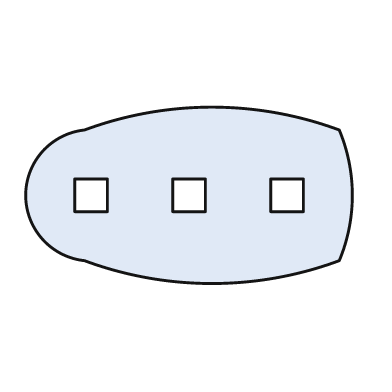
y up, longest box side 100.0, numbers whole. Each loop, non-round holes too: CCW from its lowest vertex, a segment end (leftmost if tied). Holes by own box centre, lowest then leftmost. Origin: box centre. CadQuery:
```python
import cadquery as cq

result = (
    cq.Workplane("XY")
    .moveTo(-32.0, -20.0)
    .threePointArc((7.0, -27.0), (46.0, -20.0))
    .threePointArc((50.0, 0.0), (46.0, 20.0))
    .threePointArc((7.0, 27.0), (-32.0, 20.0))
    .threePointArc((-50.0, 0.0), (-32.0, -20.0))
    .close()
    .moveTo(-35.0, -5.0)
    .lineTo(-25.0, -5.0)
    .lineTo(-25.0, 5.0)
    .lineTo(-35.0, 5.0)
    .close()
    .moveTo(-5.0, -5.0)
    .lineTo(5.0, -5.0)
    .lineTo(5.0, 5.0)
    .lineTo(-5.0, 5.0)
    .close()
    .moveTo(25.0, -5.0)
    .lineTo(35.0, -5.0)
    .lineTo(35.0, 5.0)
    .lineTo(25.0, 5.0)
    .close()
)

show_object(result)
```